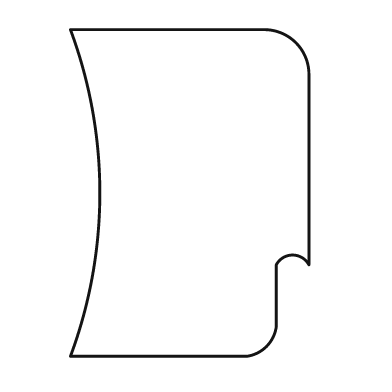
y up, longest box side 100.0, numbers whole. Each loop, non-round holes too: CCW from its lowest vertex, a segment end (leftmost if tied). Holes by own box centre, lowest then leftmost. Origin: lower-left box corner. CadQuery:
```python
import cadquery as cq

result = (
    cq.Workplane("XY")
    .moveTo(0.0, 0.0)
    .lineTo(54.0, 0.0)
    .threePointArc((60.0, 3.0), (63.0, 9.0))
    .lineTo(63.0, 28.0)
    .threePointArc((68.0, 31.0), (73.0, 28.0))
    .lineTo(73.0, 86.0)
    .threePointArc((69.0, 96.0), (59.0, 100.0))
    .lineTo(0.0, 100.0)
    .threePointArc((9.0, 50.0), (0.0, 0.0))
    .close()
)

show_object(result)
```